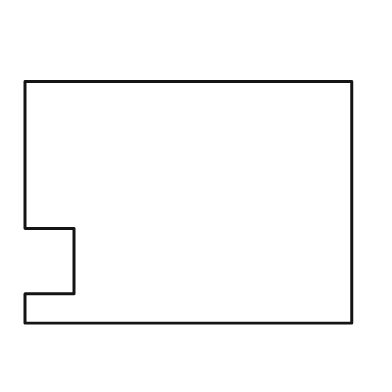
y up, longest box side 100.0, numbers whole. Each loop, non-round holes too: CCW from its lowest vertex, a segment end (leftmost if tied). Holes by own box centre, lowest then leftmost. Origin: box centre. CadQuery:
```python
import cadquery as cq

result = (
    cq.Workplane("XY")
    .moveTo(-50.0, -37.0)
    .lineTo(50.0, -37.0)
    .lineTo(50.0, 37.0)
    .lineTo(-50.0, 37.0)
    .lineTo(-50.0, -8.0)
    .lineTo(-35.0, -8.0)
    .lineTo(-35.0, -28.0)
    .lineTo(-50.0, -28.0)
    .close()
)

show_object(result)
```